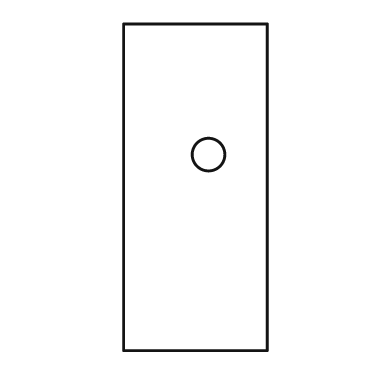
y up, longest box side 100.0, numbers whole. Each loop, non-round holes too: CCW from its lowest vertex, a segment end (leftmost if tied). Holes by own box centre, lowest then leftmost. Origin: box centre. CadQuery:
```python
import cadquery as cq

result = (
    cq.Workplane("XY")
    .moveTo(-22.0, -50.0)
    .lineTo(22.0, -50.0)
    .lineTo(22.0, 50.0)
    .lineTo(-22.0, 50.0)
    .close()
    .moveTo(4.0, 10.0)
    .circle(5.0)
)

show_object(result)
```